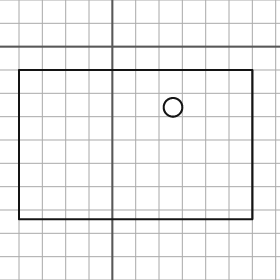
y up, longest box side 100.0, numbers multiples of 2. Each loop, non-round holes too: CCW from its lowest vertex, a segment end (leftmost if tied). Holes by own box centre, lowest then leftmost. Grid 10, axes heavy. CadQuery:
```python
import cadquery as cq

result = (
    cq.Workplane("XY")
    .moveTo(-40.0, -74.0)
    .lineTo(60.0, -74.0)
    .lineTo(60.0, -10.0)
    .lineTo(-40.0, -10.0)
    .close()
    .moveTo(26.0, -26.0)
    .circle(4.0)
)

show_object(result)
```